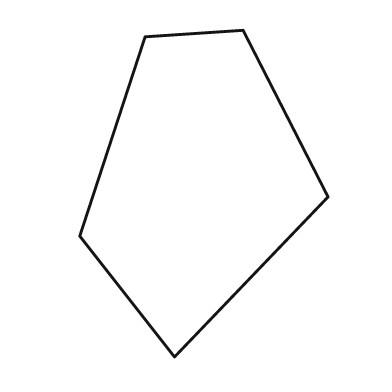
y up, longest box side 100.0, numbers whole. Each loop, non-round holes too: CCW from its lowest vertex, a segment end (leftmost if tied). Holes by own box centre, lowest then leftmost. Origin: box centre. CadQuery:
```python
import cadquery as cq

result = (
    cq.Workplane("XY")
    .moveTo(-9.0, -50.0)
    .lineTo(38.0, -1.0)
    .lineTo(12.0, 50.0)
    .lineTo(-18.0, 48.0)
    .lineTo(-38.0, -13.0)
    .close()
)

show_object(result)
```